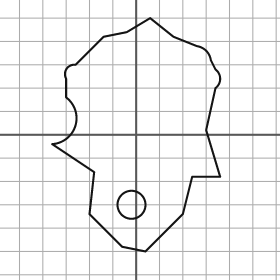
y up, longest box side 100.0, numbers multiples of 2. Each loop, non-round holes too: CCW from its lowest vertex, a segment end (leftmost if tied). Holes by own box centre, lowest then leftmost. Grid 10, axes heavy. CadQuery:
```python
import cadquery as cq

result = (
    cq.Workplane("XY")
    .moveTo(4.0, -50.0)
    .lineTo(20.0, -34.0)
    .lineTo(24.0, -18.0)
    .lineTo(36.0, -18.0)
    .lineTo(30.0, 2.0)
    .lineTo(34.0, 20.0)
    .threePointArc((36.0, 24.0), (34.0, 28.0))
    .lineTo(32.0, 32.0)
    .threePointArc((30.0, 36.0), (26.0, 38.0))
    .lineTo(16.0, 42.0)
    .lineTo(6.0, 50.0)
    .lineTo(-4.0, 44.0)
    .lineTo(-14.0, 42.0)
    .lineTo(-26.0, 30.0)
    .threePointArc((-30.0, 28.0), (-30.0, 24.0))
    .lineTo(-30.0, 16.0)
    .threePointArc((-26.0, 4.0), (-36.0, -4.0))
    .lineTo(-18.0, -16.0)
    .lineTo(-20.0, -34.0)
    .lineTo(-6.0, -48.0)
    .close()
    .moveTo(-2.0, -30.0)
    .circle(6.0)
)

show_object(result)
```